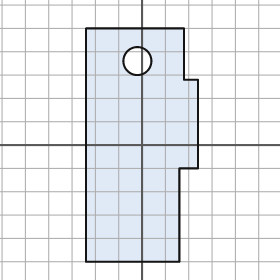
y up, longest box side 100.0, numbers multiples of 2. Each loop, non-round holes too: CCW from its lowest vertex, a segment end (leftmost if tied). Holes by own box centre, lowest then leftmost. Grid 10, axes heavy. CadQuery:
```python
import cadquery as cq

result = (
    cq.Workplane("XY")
    .moveTo(-24.0, -50.0)
    .lineTo(16.0, -50.0)
    .lineTo(16.0, -10.0)
    .lineTo(24.0, -10.0)
    .lineTo(24.0, 28.0)
    .lineTo(18.0, 28.0)
    .lineTo(18.0, 50.0)
    .lineTo(-24.0, 50.0)
    .close()
    .moveTo(-2.0, 36.0)
    .circle(6.0)
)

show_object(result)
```